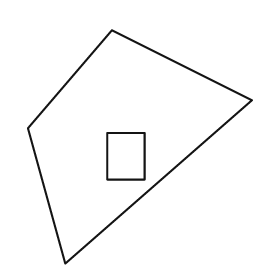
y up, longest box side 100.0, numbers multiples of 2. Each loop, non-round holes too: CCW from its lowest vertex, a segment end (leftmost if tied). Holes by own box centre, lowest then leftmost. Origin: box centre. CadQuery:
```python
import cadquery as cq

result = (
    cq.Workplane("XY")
    .moveTo(-32.0, -50.0)
    .lineTo(48.0, 20.0)
    .lineTo(-12.0, 50.0)
    .lineTo(-48.0, 8.0)
    .close()
    .moveTo(-14.0, -14.0)
    .lineTo(2.0, -14.0)
    .lineTo(2.0, 6.0)
    .lineTo(-14.0, 6.0)
    .close()
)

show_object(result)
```